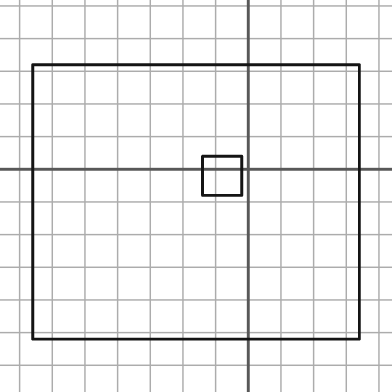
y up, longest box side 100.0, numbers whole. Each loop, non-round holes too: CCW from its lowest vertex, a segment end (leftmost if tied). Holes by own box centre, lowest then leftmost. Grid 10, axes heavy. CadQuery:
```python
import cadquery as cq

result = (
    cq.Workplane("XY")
    .moveTo(-66.0, -52.0)
    .lineTo(34.0, -52.0)
    .lineTo(34.0, 32.0)
    .lineTo(-66.0, 32.0)
    .close()
    .moveTo(-14.0, -8.0)
    .lineTo(-2.0, -8.0)
    .lineTo(-2.0, 4.0)
    .lineTo(-14.0, 4.0)
    .close()
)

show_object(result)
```